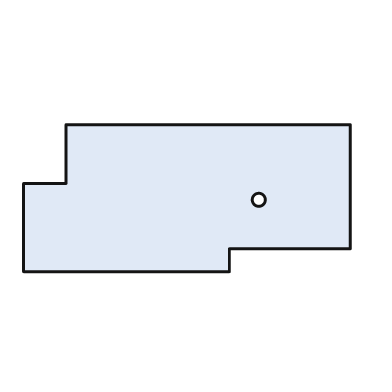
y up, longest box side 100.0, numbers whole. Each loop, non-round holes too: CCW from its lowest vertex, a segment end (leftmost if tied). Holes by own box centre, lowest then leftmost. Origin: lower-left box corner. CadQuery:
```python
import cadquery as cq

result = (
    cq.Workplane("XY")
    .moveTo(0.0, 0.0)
    .lineTo(63.0, 0.0)
    .lineTo(63.0, 7.0)
    .lineTo(100.0, 7.0)
    .lineTo(100.0, 45.0)
    .lineTo(13.0, 45.0)
    .lineTo(13.0, 27.0)
    .lineTo(0.0, 27.0)
    .close()
    .moveTo(72.0, 22.0)
    .circle(2.0)
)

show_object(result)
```